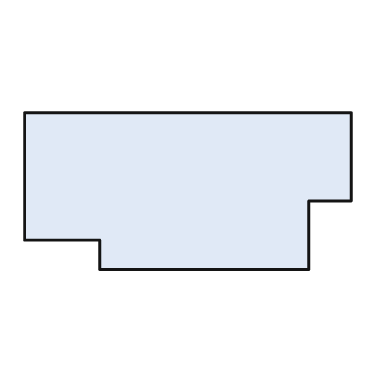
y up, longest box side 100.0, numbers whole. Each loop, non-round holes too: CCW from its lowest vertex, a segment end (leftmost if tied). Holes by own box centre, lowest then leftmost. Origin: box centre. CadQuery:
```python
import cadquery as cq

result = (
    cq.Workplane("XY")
    .moveTo(-27.0, -24.0)
    .lineTo(37.0, -24.0)
    .lineTo(37.0, -3.0)
    .lineTo(50.0, -3.0)
    .lineTo(50.0, 24.0)
    .lineTo(-50.0, 24.0)
    .lineTo(-50.0, -15.0)
    .lineTo(-27.0, -15.0)
    .close()
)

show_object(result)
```